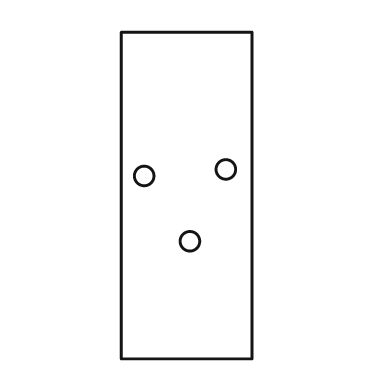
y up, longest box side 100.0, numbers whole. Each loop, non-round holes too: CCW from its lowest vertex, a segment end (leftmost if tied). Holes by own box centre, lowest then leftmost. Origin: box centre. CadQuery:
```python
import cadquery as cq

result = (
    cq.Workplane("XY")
    .moveTo(-20.0, -50.0)
    .lineTo(20.0, -50.0)
    .lineTo(20.0, 50.0)
    .lineTo(-20.0, 50.0)
    .close()
    .moveTo(1.0, -14.0)
    .circle(3.0)
    .moveTo(-13.0, 6.0)
    .circle(3.0)
    .moveTo(12.0, 8.0)
    .circle(3.0)
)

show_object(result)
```